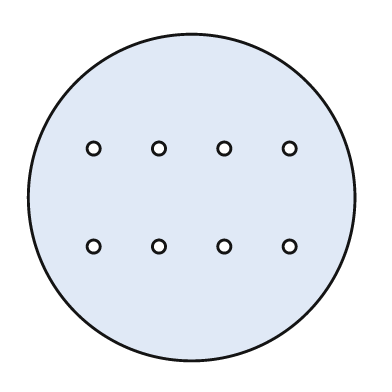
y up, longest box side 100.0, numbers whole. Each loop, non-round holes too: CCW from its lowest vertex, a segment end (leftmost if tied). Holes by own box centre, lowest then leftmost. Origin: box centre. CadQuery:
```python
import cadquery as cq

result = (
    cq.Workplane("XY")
    .moveTo(0.0, 0.0)
    .circle(50.0)
    .moveTo(-30.0, -15.0)
    .circle(2.0)
    .moveTo(-10.0, -15.0)
    .circle(2.0)
    .moveTo(10.0, -15.0)
    .circle(2.0)
    .moveTo(30.0, -15.0)
    .circle(2.0)
    .moveTo(-30.0, 15.0)
    .circle(2.0)
    .moveTo(-10.0, 15.0)
    .circle(2.0)
    .moveTo(10.0, 15.0)
    .circle(2.0)
    .moveTo(30.0, 15.0)
    .circle(2.0)
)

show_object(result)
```